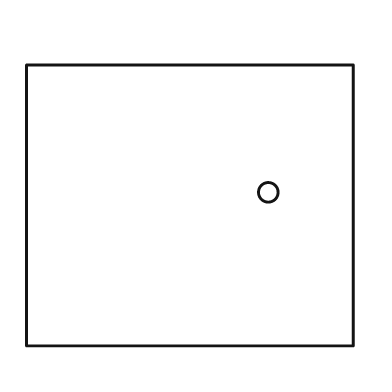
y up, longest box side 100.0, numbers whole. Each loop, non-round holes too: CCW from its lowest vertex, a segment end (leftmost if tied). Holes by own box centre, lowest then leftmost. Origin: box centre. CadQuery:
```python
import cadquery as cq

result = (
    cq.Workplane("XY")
    .moveTo(-50.0, -43.0)
    .lineTo(50.0, -43.0)
    .lineTo(50.0, 43.0)
    .lineTo(-50.0, 43.0)
    .close()
    .moveTo(24.0, 4.0)
    .circle(3.0)
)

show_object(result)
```